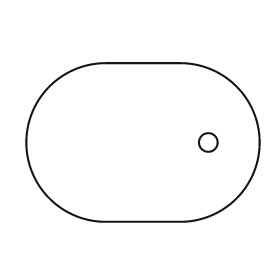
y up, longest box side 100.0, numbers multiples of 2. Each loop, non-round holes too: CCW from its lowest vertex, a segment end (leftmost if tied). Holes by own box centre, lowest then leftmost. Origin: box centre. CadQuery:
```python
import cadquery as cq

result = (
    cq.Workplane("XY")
    .moveTo(-16.0, -34.0)
    .lineTo(16.0, -34.0)
    .threePointArc((50.0, 0.0), (16.0, 34.0))
    .lineTo(-16.0, 34.0)
    .threePointArc((-50.0, 0.0), (-16.0, -34.0))
    .close()
    .moveTo(28.0, 0.0)
    .circle(4.0)
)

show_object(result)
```